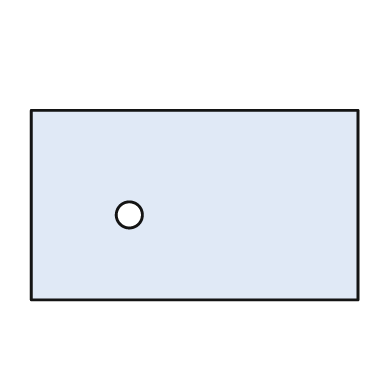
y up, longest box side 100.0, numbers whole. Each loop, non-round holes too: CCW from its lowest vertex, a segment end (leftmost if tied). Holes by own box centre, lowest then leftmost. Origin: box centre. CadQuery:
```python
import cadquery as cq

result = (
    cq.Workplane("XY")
    .moveTo(-50.0, -29.0)
    .lineTo(50.0, -29.0)
    .lineTo(50.0, 29.0)
    .lineTo(-50.0, 29.0)
    .close()
    .moveTo(-20.0, -3.0)
    .circle(4.0)
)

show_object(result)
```